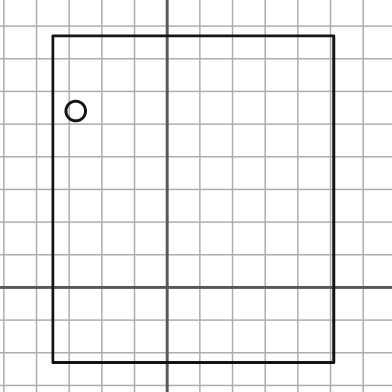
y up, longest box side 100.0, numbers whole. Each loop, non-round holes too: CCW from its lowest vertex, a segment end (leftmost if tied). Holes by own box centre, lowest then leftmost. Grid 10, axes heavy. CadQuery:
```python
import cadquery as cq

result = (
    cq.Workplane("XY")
    .moveTo(-35.0, -23.0)
    .lineTo(51.0, -23.0)
    .lineTo(51.0, 77.0)
    .lineTo(-35.0, 77.0)
    .close()
    .moveTo(-28.0, 54.0)
    .circle(3.0)
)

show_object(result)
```